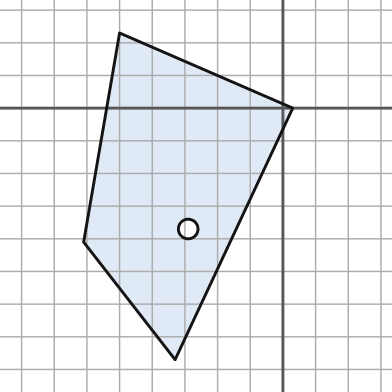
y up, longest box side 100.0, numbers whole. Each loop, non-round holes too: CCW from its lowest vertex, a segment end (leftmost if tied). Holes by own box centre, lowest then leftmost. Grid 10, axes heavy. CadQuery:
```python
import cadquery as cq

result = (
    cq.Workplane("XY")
    .moveTo(-33.0, -77.0)
    .lineTo(3.0, 0.0)
    .lineTo(-50.0, 23.0)
    .lineTo(-61.0, -41.0)
    .close()
    .moveTo(-29.0, -37.0)
    .circle(3.0)
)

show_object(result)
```